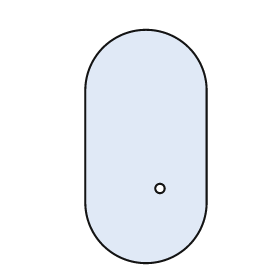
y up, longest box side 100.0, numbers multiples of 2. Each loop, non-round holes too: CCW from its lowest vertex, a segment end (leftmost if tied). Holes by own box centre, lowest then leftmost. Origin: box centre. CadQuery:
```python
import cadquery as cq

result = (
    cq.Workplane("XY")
    .moveTo(-26.0, -24.0)
    .threePointArc((0.0, -50.0), (26.0, -24.0))
    .lineTo(26.0, 24.0)
    .threePointArc((0.0, 50.0), (-26.0, 24.0))
    .close()
    .moveTo(6.0, -18.0)
    .circle(2.0)
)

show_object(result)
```